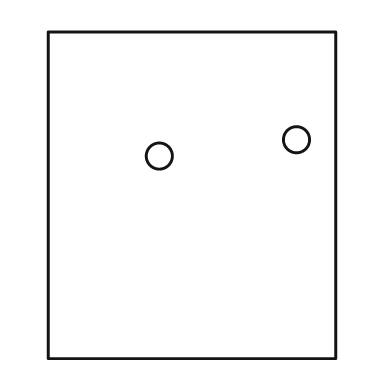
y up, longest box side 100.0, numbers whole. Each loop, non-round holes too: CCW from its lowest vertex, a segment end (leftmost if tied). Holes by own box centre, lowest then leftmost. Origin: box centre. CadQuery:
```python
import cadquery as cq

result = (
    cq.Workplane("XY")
    .moveTo(-44.0, -50.0)
    .lineTo(44.0, -50.0)
    .lineTo(44.0, 50.0)
    .lineTo(-44.0, 50.0)
    .close()
    .moveTo(-10.0, 12.0)
    .circle(4.0)
    .moveTo(32.0, 17.0)
    .circle(4.0)
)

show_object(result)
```